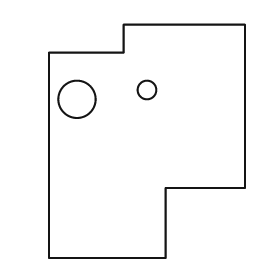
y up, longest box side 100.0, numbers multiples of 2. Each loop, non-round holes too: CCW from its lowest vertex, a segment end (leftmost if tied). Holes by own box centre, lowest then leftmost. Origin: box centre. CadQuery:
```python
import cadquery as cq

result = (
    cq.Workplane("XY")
    .moveTo(-42.0, -50.0)
    .lineTo(8.0, -50.0)
    .lineTo(8.0, -20.0)
    .lineTo(42.0, -20.0)
    .lineTo(42.0, 50.0)
    .lineTo(-10.0, 50.0)
    .lineTo(-10.0, 38.0)
    .lineTo(-42.0, 38.0)
    .close()
    .moveTo(-30.0, 18.0)
    .circle(8.0)
    .moveTo(0.0, 22.0)
    .circle(4.0)
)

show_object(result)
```